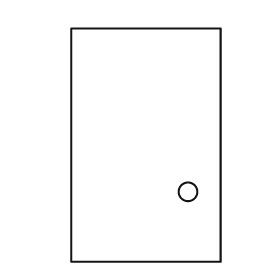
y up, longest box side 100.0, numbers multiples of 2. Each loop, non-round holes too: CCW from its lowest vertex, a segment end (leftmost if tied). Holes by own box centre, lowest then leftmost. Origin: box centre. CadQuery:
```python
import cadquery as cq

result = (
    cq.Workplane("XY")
    .moveTo(-32.0, -50.0)
    .lineTo(32.0, -50.0)
    .lineTo(32.0, 50.0)
    .lineTo(-32.0, 50.0)
    .close()
    .moveTo(18.0, -20.0)
    .circle(4.0)
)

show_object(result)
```